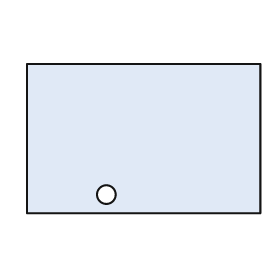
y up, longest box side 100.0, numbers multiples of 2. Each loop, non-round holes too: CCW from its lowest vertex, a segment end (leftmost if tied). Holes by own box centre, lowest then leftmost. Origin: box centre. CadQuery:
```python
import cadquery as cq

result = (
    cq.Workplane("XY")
    .moveTo(-50.0, -32.0)
    .lineTo(50.0, -32.0)
    .lineTo(50.0, 32.0)
    .lineTo(-50.0, 32.0)
    .close()
    .moveTo(-16.0, -24.0)
    .circle(4.0)
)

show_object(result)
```